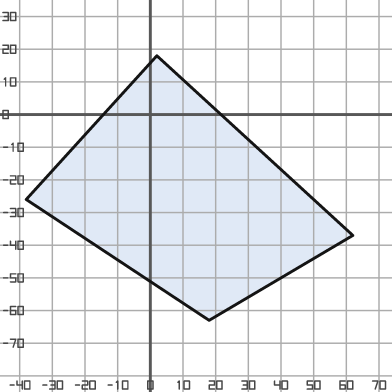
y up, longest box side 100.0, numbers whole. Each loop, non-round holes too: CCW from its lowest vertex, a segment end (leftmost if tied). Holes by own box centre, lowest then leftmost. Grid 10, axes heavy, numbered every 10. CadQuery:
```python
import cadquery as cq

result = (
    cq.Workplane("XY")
    .moveTo(18.0, -63.0)
    .lineTo(62.0, -37.0)
    .lineTo(2.0, 18.0)
    .lineTo(-38.0, -26.0)
    .close()
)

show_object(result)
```